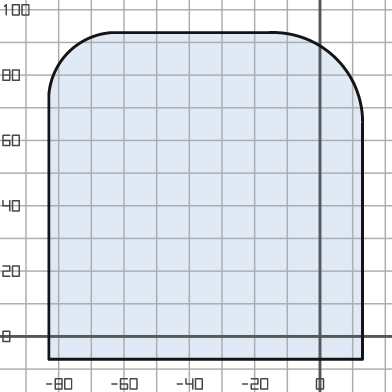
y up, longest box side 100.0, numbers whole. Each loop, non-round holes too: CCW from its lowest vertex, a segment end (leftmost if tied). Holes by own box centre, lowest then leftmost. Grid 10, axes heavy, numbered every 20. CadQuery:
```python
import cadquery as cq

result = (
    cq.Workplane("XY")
    .moveTo(-83.0, -7.0)
    .lineTo(13.0, -7.0)
    .lineTo(13.0, 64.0)
    .threePointArc((5.0, 85.0), (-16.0, 93.0))
    .lineTo(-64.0, 93.0)
    .threePointArc((-77.0, 87.0), (-83.0, 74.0))
    .close()
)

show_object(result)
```